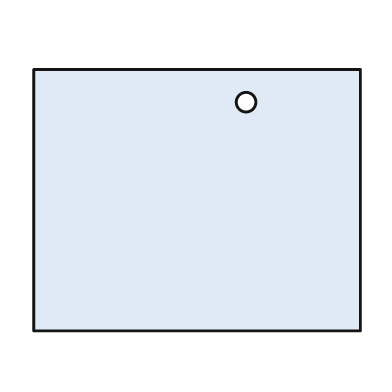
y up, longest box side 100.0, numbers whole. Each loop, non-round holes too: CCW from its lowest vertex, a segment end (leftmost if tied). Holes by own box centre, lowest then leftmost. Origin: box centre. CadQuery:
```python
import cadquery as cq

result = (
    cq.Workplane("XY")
    .moveTo(-50.0, -40.0)
    .lineTo(50.0, -40.0)
    .lineTo(50.0, 40.0)
    .lineTo(-50.0, 40.0)
    .close()
    .moveTo(15.0, 30.0)
    .circle(3.0)
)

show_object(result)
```